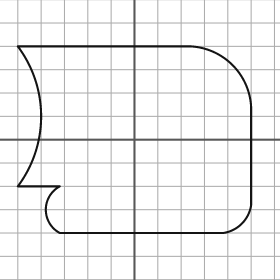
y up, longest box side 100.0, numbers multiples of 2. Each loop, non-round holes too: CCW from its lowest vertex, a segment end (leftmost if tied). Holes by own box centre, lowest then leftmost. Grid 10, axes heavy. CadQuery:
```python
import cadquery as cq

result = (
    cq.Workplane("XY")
    .moveTo(-32.0, -40.0)
    .lineTo(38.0, -40.0)
    .threePointArc((46.0, -36.0), (50.0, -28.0))
    .lineTo(50.0, 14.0)
    .threePointArc((42.0, 32.0), (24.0, 40.0))
    .lineTo(-50.0, 40.0)
    .threePointArc((-40.0, 10.0), (-50.0, -20.0))
    .lineTo(-32.0, -20.0)
    .threePointArc((-38.0, -30.0), (-32.0, -40.0))
    .close()
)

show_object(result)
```